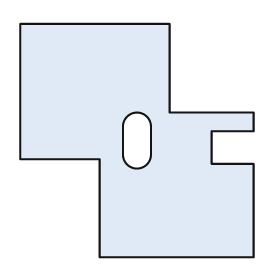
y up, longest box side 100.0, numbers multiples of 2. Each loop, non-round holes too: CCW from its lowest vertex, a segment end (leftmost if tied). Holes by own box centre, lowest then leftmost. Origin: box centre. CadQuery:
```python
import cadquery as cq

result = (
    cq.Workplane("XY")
    .moveTo(-16.0, -50.0)
    .lineTo(50.0, -50.0)
    .lineTo(50.0, -10.0)
    .lineTo(32.0, -10.0)
    .lineTo(32.0, 4.0)
    .lineTo(50.0, 4.0)
    .lineTo(50.0, 12.0)
    .lineTo(14.0, 12.0)
    .lineTo(14.0, 50.0)
    .lineTo(-50.0, 50.0)
    .lineTo(-50.0, -8.0)
    .lineTo(-16.0, -8.0)
    .close()
    .moveTo(-6.0, -6.0)
    .threePointArc((0.0, -12.0), (6.0, -6.0))
    .lineTo(6.0, 6.0)
    .threePointArc((0.0, 12.0), (-6.0, 6.0))
    .close()
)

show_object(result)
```